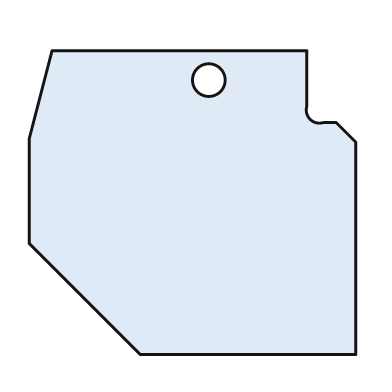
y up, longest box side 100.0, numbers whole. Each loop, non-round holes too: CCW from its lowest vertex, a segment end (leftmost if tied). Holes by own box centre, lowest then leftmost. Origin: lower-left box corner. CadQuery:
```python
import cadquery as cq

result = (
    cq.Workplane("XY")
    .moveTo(34.0, 0.0)
    .lineTo(100.0, 0.0)
    .lineTo(100.0, 65.0)
    .lineTo(94.0, 71.0)
    .lineTo(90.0, 71.0)
    .threePointArc((86.0, 72.0), (85.0, 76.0))
    .lineTo(85.0, 93.0)
    .lineTo(7.0, 93.0)
    .lineTo(0.0, 66.0)
    .lineTo(0.0, 34.0)
    .close()
    .moveTo(55.0, 84.0)
    .circle(5.0)
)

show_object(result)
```